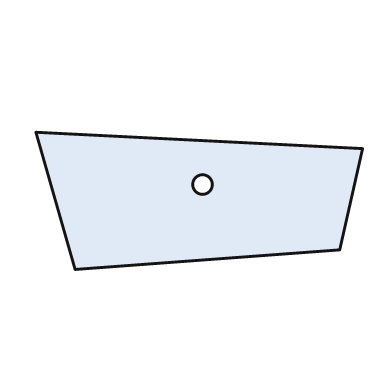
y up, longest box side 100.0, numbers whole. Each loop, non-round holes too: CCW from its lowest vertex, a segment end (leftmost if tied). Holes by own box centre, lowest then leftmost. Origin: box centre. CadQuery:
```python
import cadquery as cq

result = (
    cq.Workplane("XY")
    .moveTo(-38.0, -21.0)
    .lineTo(43.0, -15.0)
    .lineTo(50.0, 16.0)
    .lineTo(-50.0, 21.0)
    .close()
    .moveTo(1.0, 5.0)
    .circle(3.0)
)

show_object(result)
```